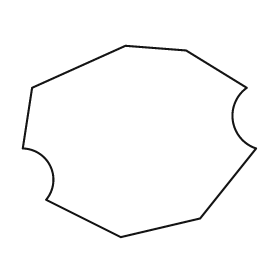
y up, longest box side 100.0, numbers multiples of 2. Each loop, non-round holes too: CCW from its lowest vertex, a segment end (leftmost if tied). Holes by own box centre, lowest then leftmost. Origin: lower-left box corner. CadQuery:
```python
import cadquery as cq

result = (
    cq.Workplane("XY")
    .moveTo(42.0, 0.0)
    .lineTo(76.0, 8.0)
    .lineTo(100.0, 38.0)
    .threePointArc((90.0, 50.0), (96.0, 64.0))
    .lineTo(70.0, 80.0)
    .lineTo(44.0, 82.0)
    .lineTo(4.0, 64.0)
    .lineTo(0.0, 38.0)
    .threePointArc((12.0, 30.0), (10.0, 16.0))
    .close()
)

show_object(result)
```